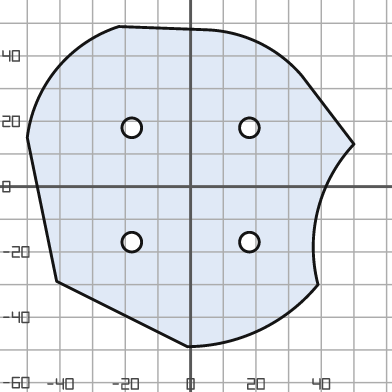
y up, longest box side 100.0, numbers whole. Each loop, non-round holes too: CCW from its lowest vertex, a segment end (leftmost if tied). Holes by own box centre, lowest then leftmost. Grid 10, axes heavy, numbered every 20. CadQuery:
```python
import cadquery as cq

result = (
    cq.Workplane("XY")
    .moveTo(-1.0, -49.0)
    .threePointArc((21.0, -44.0), (39.0, -30.0))
    .threePointArc((39.0, -7.0), (50.0, 13.0))
    .lineTo(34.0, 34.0)
    .threePointArc((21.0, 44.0), (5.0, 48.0))
    .lineTo(-22.0, 49.0)
    .threePointArc((-41.0, 36.0), (-50.0, 15.0))
    .lineTo(-41.0, -29.0)
    .close()
    .moveTo(-18.0, -17.0)
    .circle(3.0)
    .moveTo(18.0, -17.0)
    .circle(3.0)
    .moveTo(-18.0, 18.0)
    .circle(3.0)
    .moveTo(18.0, 18.0)
    .circle(3.0)
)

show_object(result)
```